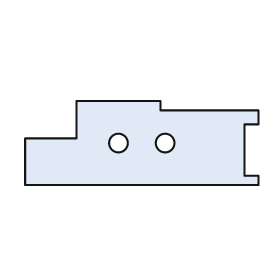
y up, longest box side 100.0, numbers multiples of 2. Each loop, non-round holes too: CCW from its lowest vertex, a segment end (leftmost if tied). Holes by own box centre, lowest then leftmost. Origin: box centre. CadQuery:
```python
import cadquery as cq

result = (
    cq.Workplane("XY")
    .moveTo(-50.0, -18.0)
    .lineTo(50.0, -18.0)
    .lineTo(50.0, -14.0)
    .lineTo(44.0, -14.0)
    .lineTo(44.0, 8.0)
    .lineTo(50.0, 8.0)
    .lineTo(50.0, 14.0)
    .lineTo(8.0, 14.0)
    .lineTo(8.0, 18.0)
    .lineTo(-28.0, 18.0)
    .lineTo(-28.0, 2.0)
    .lineTo(-50.0, 2.0)
    .close()
    .moveTo(-10.0, 0.0)
    .circle(4.0)
    .moveTo(10.0, 0.0)
    .circle(4.0)
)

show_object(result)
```